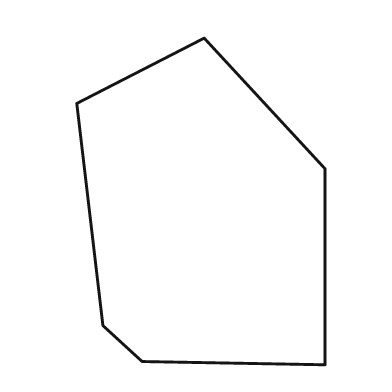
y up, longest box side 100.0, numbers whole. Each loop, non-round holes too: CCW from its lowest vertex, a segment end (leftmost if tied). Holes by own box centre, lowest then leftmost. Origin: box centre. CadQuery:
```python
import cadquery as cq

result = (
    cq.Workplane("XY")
    .moveTo(38.0, -50.0)
    .lineTo(38.0, 10.0)
    .lineTo(1.0, 50.0)
    .lineTo(-38.0, 30.0)
    .lineTo(-30.0, -38.0)
    .lineTo(-18.0, -49.0)
    .close()
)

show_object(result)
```